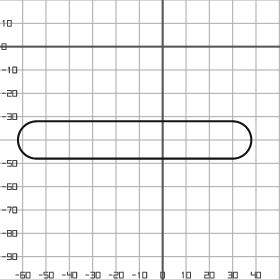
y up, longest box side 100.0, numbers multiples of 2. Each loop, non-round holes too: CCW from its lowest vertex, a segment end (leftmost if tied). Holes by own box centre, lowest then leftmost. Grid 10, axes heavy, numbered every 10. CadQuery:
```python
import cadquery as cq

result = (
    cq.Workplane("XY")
    .moveTo(-54.0, -48.0)
    .lineTo(30.0, -48.0)
    .threePointArc((38.0, -40.0), (30.0, -32.0))
    .lineTo(-54.0, -32.0)
    .threePointArc((-62.0, -40.0), (-54.0, -48.0))
    .close()
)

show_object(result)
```